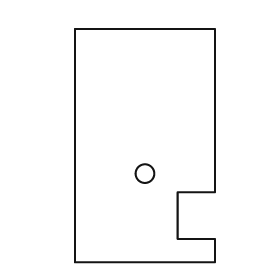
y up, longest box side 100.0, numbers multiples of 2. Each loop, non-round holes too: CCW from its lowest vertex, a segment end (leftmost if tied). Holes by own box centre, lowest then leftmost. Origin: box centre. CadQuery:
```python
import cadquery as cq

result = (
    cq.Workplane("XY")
    .moveTo(-30.0, -50.0)
    .lineTo(30.0, -50.0)
    .lineTo(30.0, -40.0)
    .lineTo(14.0, -40.0)
    .lineTo(14.0, -20.0)
    .lineTo(30.0, -20.0)
    .lineTo(30.0, 50.0)
    .lineTo(-30.0, 50.0)
    .close()
    .moveTo(0.0, -12.0)
    .circle(4.0)
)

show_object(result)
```